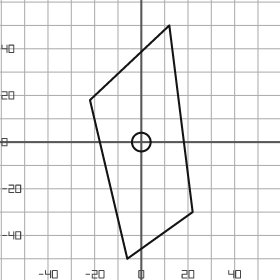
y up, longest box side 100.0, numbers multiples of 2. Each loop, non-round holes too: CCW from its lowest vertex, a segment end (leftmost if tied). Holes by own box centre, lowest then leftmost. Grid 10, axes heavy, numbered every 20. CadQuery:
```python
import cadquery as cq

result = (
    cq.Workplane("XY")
    .moveTo(-6.0, -50.0)
    .lineTo(22.0, -30.0)
    .lineTo(12.0, 50.0)
    .lineTo(-22.0, 18.0)
    .close()
    .moveTo(0.0, 0.0)
    .circle(4.0)
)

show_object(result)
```